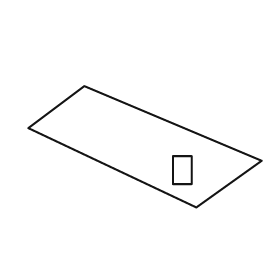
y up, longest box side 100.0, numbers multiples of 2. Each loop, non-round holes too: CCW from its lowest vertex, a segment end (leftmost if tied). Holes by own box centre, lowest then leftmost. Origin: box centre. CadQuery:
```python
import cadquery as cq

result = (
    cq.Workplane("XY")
    .moveTo(22.0, -26.0)
    .lineTo(50.0, -6.0)
    .lineTo(-26.0, 26.0)
    .lineTo(-50.0, 8.0)
    .close()
    .moveTo(12.0, -16.0)
    .lineTo(20.0, -16.0)
    .lineTo(20.0, -4.0)
    .lineTo(12.0, -4.0)
    .close()
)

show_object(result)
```